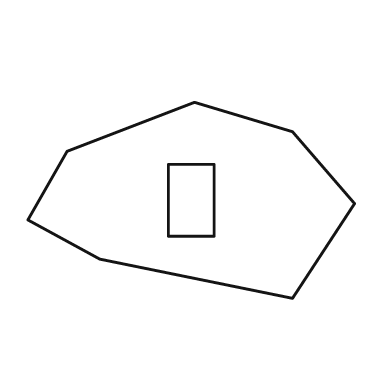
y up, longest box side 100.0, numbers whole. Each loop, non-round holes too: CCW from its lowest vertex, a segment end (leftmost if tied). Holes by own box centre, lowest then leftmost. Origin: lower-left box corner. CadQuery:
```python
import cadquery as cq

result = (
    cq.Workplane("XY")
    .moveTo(81.0, 0.0)
    .lineTo(100.0, 29.0)
    .lineTo(81.0, 51.0)
    .lineTo(51.0, 60.0)
    .lineTo(12.0, 45.0)
    .lineTo(0.0, 24.0)
    .lineTo(22.0, 12.0)
    .close()
    .moveTo(43.0, 19.0)
    .lineTo(57.0, 19.0)
    .lineTo(57.0, 41.0)
    .lineTo(43.0, 41.0)
    .close()
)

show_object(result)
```